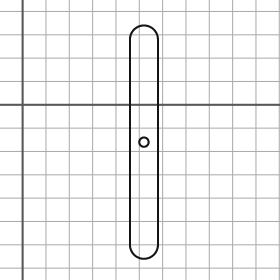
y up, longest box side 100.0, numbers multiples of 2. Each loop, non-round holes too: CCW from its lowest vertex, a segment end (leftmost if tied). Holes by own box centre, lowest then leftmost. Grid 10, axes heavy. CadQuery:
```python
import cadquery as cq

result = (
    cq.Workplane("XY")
    .moveTo(46.0, -60.0)
    .threePointArc((52.0, -66.0), (58.0, -60.0))
    .lineTo(58.0, 28.0)
    .threePointArc((52.0, 34.0), (46.0, 28.0))
    .close()
    .moveTo(52.0, -16.0)
    .circle(2.0)
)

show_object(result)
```